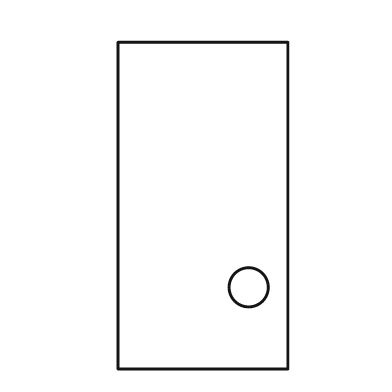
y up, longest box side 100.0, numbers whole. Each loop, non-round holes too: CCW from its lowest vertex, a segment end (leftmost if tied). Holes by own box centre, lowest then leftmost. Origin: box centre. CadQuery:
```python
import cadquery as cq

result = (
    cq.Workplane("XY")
    .moveTo(-26.0, -50.0)
    .lineTo(26.0, -50.0)
    .lineTo(26.0, 50.0)
    .lineTo(-26.0, 50.0)
    .close()
    .moveTo(14.0, -25.0)
    .circle(6.0)
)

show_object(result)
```